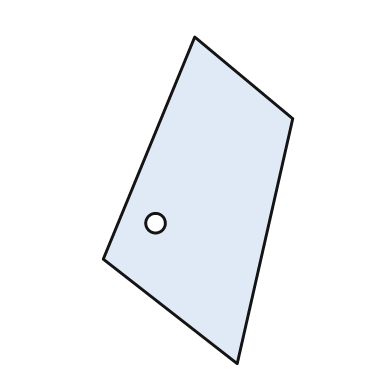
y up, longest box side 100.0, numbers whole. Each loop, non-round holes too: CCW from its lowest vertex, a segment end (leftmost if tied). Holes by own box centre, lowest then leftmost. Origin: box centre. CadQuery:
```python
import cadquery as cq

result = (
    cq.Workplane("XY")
    .moveTo(12.0, -50.0)
    .lineTo(29.0, 25.0)
    .lineTo(-1.0, 50.0)
    .lineTo(-29.0, -18.0)
    .close()
    .moveTo(-13.0, -7.0)
    .circle(3.0)
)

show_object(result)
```